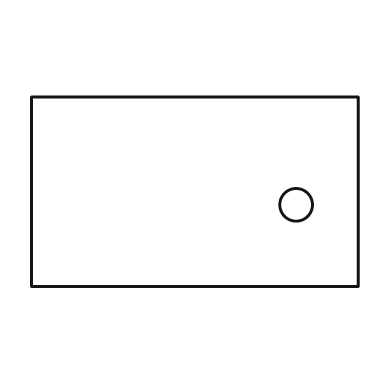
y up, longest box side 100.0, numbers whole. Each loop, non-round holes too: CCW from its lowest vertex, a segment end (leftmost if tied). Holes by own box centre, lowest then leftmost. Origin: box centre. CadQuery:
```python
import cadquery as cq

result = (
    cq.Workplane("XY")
    .moveTo(-50.0, -29.0)
    .lineTo(50.0, -29.0)
    .lineTo(50.0, 29.0)
    .lineTo(-50.0, 29.0)
    .close()
    .moveTo(31.0, -4.0)
    .circle(5.0)
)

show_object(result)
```